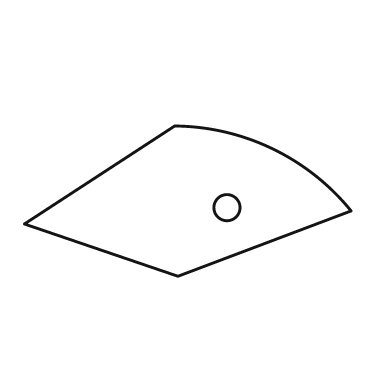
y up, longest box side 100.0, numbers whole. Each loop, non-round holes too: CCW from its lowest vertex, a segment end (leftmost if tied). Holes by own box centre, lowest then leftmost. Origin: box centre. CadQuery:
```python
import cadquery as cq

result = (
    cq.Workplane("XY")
    .moveTo(-3.0, -23.0)
    .lineTo(50.0, -3.0)
    .threePointArc((26.0, 16.0), (-4.0, 23.0))
    .lineTo(-50.0, -7.0)
    .close()
    .moveTo(12.0, -2.0)
    .circle(4.0)
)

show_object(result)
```